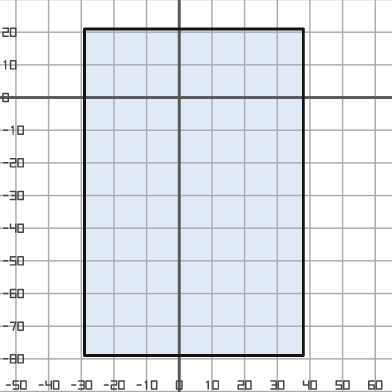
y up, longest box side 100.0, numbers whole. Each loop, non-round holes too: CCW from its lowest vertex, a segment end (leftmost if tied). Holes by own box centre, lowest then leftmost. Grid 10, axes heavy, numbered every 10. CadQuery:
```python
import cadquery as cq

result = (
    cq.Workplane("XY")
    .moveTo(-29.0, -79.0)
    .lineTo(38.0, -79.0)
    .lineTo(38.0, 21.0)
    .lineTo(-29.0, 21.0)
    .close()
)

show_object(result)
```